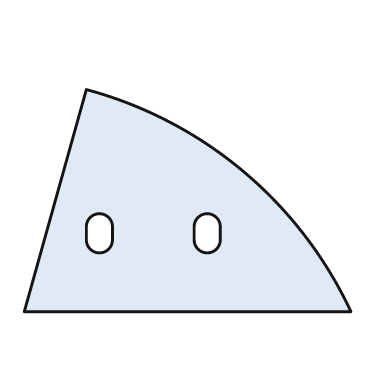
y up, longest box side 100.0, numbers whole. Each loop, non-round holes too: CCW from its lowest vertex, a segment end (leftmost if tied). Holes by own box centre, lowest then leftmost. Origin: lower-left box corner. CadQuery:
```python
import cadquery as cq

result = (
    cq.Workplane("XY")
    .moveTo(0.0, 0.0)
    .lineTo(100.0, 0.0)
    .threePointArc((67.0, 43.0), (19.0, 68.0))
    .close()
    .moveTo(19.0, 22.0)
    .threePointArc((23.0, 18.0), (27.0, 22.0))
    .lineTo(27.0, 26.0)
    .threePointArc((23.0, 30.0), (19.0, 26.0))
    .close()
    .moveTo(52.0, 22.0)
    .threePointArc((56.0, 18.0), (60.0, 22.0))
    .lineTo(60.0, 26.0)
    .threePointArc((56.0, 30.0), (52.0, 26.0))
    .close()
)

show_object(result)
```